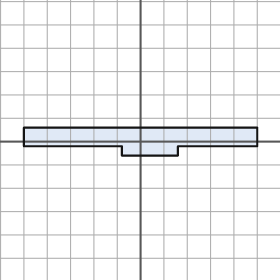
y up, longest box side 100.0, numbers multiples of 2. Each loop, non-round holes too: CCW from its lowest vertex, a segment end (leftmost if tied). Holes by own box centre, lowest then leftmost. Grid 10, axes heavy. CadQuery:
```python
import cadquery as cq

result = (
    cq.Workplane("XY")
    .moveTo(-8.0, -6.0)
    .lineTo(16.0, -6.0)
    .lineTo(16.0, -2.0)
    .lineTo(50.0, -2.0)
    .lineTo(50.0, 6.0)
    .lineTo(-50.0, 6.0)
    .lineTo(-50.0, -2.0)
    .lineTo(-8.0, -2.0)
    .close()
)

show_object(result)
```